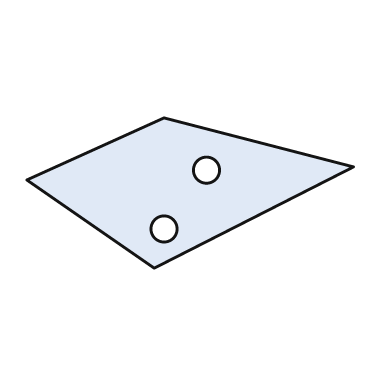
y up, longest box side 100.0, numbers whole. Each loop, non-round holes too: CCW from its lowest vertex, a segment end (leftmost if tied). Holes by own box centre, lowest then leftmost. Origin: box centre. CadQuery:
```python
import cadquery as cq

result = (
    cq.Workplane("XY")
    .moveTo(-11.0, -23.0)
    .lineTo(50.0, 8.0)
    .lineTo(-8.0, 23.0)
    .lineTo(-50.0, 4.0)
    .close()
    .moveTo(-8.0, -11.0)
    .circle(4.0)
    .moveTo(5.0, 7.0)
    .circle(4.0)
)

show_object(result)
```